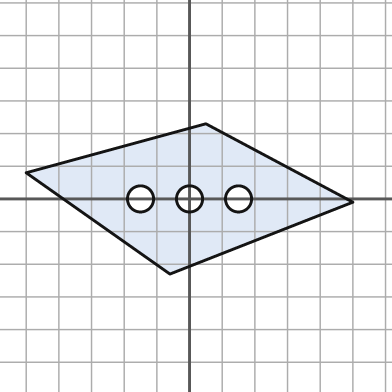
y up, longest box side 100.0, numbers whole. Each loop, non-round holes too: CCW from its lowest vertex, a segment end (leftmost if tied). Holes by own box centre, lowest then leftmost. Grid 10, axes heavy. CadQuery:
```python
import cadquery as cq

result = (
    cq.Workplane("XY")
    .moveTo(-6.0, -23.0)
    .lineTo(50.0, -1.0)
    .lineTo(5.0, 23.0)
    .lineTo(-50.0, 8.0)
    .close()
    .moveTo(-15.0, 0.0)
    .circle(4.0)
    .moveTo(0.0, 0.0)
    .circle(4.0)
    .moveTo(15.0, 0.0)
    .circle(4.0)
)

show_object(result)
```